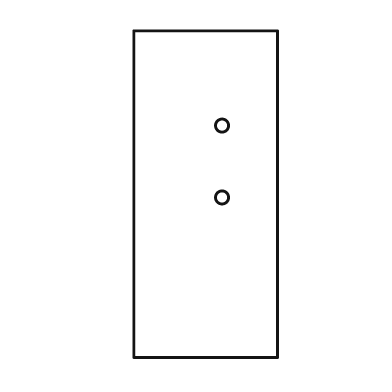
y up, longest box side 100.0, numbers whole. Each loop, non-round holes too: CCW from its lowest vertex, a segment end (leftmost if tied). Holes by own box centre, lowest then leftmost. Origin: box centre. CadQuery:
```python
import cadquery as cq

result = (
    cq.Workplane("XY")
    .moveTo(-22.0, -50.0)
    .lineTo(22.0, -50.0)
    .lineTo(22.0, 50.0)
    .lineTo(-22.0, 50.0)
    .close()
    .moveTo(5.0, -1.0)
    .circle(2.0)
    .moveTo(5.0, 21.0)
    .circle(2.0)
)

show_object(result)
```